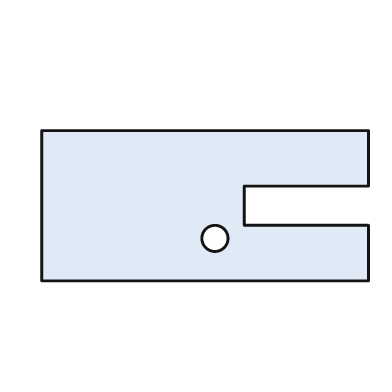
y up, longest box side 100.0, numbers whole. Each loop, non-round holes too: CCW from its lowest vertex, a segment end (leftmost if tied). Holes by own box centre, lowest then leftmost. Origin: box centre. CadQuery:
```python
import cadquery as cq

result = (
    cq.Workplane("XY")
    .moveTo(-50.0, -23.0)
    .lineTo(50.0, -23.0)
    .lineTo(50.0, -6.0)
    .lineTo(12.0, -6.0)
    .lineTo(12.0, 6.0)
    .lineTo(50.0, 6.0)
    .lineTo(50.0, 23.0)
    .lineTo(-50.0, 23.0)
    .close()
    .moveTo(3.0, -10.0)
    .circle(4.0)
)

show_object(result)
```